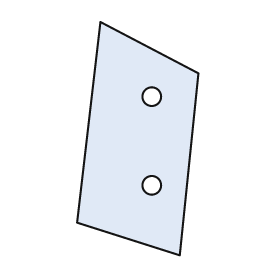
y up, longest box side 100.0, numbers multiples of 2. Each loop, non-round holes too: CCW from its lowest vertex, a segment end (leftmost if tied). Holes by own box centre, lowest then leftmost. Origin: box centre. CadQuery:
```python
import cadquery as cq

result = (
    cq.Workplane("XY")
    .moveTo(18.0, -50.0)
    .lineTo(26.0, 28.0)
    .lineTo(-16.0, 50.0)
    .lineTo(-26.0, -36.0)
    .close()
    .moveTo(6.0, -20.0)
    .circle(4.0)
    .moveTo(6.0, 18.0)
    .circle(4.0)
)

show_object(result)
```